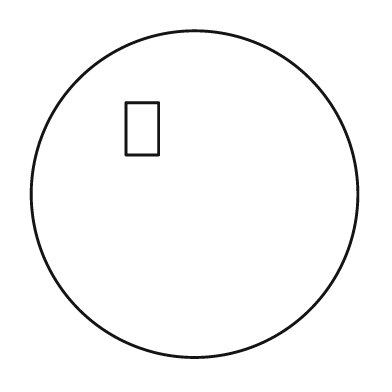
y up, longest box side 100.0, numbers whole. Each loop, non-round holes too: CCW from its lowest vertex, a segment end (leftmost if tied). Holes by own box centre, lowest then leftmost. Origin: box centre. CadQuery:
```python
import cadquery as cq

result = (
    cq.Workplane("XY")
    .moveTo(0.0, 0.0)
    .circle(50.0)
    .moveTo(-21.0, 12.0)
    .lineTo(-11.0, 12.0)
    .lineTo(-11.0, 28.0)
    .lineTo(-21.0, 28.0)
    .close()
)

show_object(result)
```